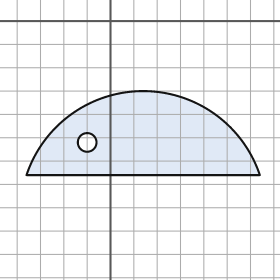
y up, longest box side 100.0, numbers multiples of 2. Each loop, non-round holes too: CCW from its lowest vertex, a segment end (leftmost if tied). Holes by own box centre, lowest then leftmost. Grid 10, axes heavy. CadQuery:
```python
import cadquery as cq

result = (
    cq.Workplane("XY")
    .moveTo(-36.0, -66.0)
    .lineTo(64.0, -66.0)
    .threePointArc((14.0, -30.0), (-36.0, -66.0))
    .close()
    .moveTo(-10.0, -52.0)
    .circle(4.0)
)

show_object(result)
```